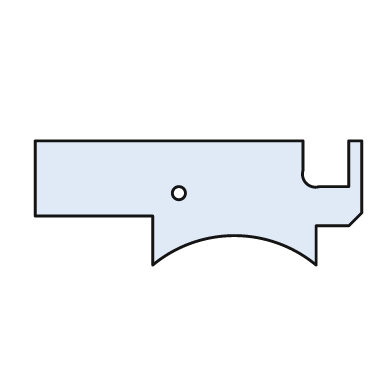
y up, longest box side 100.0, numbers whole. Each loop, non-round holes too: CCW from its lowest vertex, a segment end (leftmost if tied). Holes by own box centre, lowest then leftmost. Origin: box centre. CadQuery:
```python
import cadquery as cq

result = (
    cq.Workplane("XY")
    .moveTo(-14.0, -19.0)
    .threePointArc((11.0, -10.0), (36.0, -19.0))
    .lineTo(36.0, -7.0)
    .lineTo(46.0, -7.0)
    .lineTo(50.0, -3.0)
    .lineTo(50.0, 19.0)
    .lineTo(46.0, 19.0)
    .lineTo(46.0, 5.0)
    .lineTo(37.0, 5.0)
    .threePointArc((33.0, 6.0), (32.0, 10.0))
    .lineTo(32.0, 19.0)
    .lineTo(-50.0, 19.0)
    .lineTo(-50.0, -4.0)
    .lineTo(-14.0, -4.0)
    .close()
    .moveTo(-6.0, 3.0)
    .circle(2.0)
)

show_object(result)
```